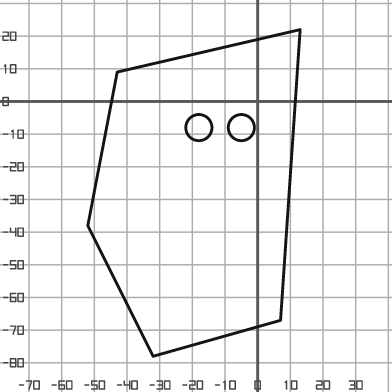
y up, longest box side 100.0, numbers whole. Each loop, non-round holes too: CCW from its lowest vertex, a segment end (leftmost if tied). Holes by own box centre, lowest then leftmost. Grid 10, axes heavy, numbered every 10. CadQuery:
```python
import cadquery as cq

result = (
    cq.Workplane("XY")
    .moveTo(-32.0, -78.0)
    .lineTo(7.0, -67.0)
    .lineTo(13.0, 22.0)
    .lineTo(-43.0, 9.0)
    .lineTo(-52.0, -38.0)
    .close()
    .moveTo(-18.0, -8.0)
    .circle(4.0)
    .moveTo(-5.0, -8.0)
    .circle(4.0)
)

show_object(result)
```